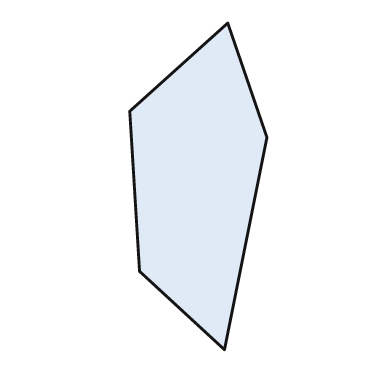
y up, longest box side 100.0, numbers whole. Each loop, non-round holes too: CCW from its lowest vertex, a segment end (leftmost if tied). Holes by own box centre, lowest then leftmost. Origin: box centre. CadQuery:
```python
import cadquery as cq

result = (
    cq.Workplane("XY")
    .moveTo(8.0, -50.0)
    .lineTo(21.0, 15.0)
    .lineTo(9.0, 50.0)
    .lineTo(-21.0, 23.0)
    .lineTo(-18.0, -26.0)
    .close()
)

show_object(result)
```